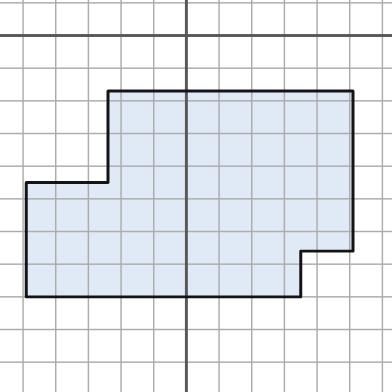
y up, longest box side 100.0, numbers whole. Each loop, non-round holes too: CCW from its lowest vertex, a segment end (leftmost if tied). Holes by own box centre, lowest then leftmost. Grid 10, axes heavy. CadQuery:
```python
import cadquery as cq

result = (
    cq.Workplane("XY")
    .moveTo(-49.0, -80.0)
    .lineTo(35.0, -80.0)
    .lineTo(35.0, -66.0)
    .lineTo(51.0, -66.0)
    .lineTo(51.0, -17.0)
    .lineTo(-24.0, -17.0)
    .lineTo(-24.0, -45.0)
    .lineTo(-49.0, -45.0)
    .close()
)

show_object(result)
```